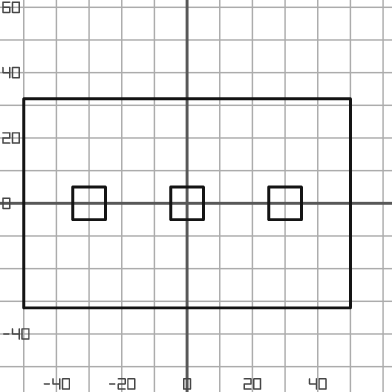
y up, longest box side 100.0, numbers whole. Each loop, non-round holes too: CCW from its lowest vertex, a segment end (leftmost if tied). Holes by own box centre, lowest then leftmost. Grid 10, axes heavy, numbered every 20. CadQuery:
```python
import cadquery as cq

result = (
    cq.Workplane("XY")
    .moveTo(-50.0, -32.0)
    .lineTo(50.0, -32.0)
    .lineTo(50.0, 32.0)
    .lineTo(-50.0, 32.0)
    .close()
    .moveTo(-35.0, -5.0)
    .lineTo(-25.0, -5.0)
    .lineTo(-25.0, 5.0)
    .lineTo(-35.0, 5.0)
    .close()
    .moveTo(-5.0, -5.0)
    .lineTo(5.0, -5.0)
    .lineTo(5.0, 5.0)
    .lineTo(-5.0, 5.0)
    .close()
    .moveTo(25.0, -5.0)
    .lineTo(35.0, -5.0)
    .lineTo(35.0, 5.0)
    .lineTo(25.0, 5.0)
    .close()
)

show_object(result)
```